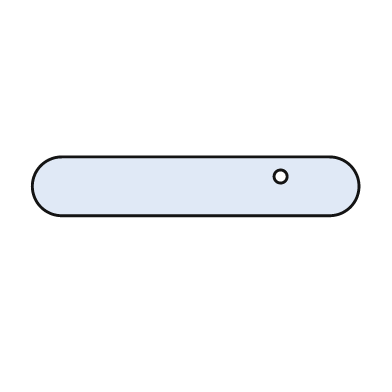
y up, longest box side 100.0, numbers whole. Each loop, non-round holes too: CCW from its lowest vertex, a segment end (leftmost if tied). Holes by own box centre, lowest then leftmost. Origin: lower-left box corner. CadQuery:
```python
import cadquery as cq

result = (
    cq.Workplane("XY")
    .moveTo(9.0, 0.0)
    .lineTo(91.0, 0.0)
    .threePointArc((100.0, 9.0), (91.0, 18.0))
    .lineTo(9.0, 18.0)
    .threePointArc((0.0, 9.0), (9.0, 0.0))
    .close()
    .moveTo(76.0, 12.0)
    .circle(2.0)
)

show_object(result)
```